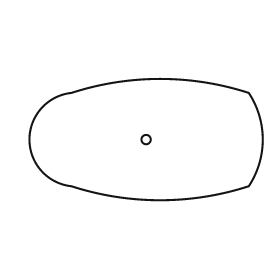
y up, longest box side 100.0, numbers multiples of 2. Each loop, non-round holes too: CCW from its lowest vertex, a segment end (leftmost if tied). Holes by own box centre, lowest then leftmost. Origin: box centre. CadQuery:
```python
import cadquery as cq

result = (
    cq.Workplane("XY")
    .moveTo(-32.0, -20.0)
    .threePointArc((6.0, -26.0), (44.0, -20.0))
    .threePointArc((50.0, 0.0), (44.0, 20.0))
    .threePointArc((6.0, 26.0), (-32.0, 20.0))
    .threePointArc((-50.0, 0.0), (-32.0, -20.0))
    .close()
    .moveTo(0.0, 0.0)
    .circle(2.0)
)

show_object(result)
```